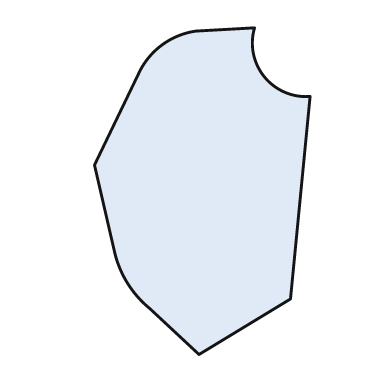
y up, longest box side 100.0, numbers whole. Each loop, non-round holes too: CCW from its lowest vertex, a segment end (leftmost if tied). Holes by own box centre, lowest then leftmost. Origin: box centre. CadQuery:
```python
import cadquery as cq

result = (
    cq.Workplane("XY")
    .moveTo(-1.0, -50.0)
    .lineTo(27.0, -33.0)
    .lineTo(33.0, 29.0)
    .threePointArc((19.0, 35.0), (16.0, 50.0))
    .lineTo(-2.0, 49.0)
    .threePointArc((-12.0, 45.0), (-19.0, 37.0))
    .lineTo(-33.0, 8.0)
    .lineTo(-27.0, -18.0)
    .threePointArc((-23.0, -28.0), (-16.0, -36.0))
    .close()
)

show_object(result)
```